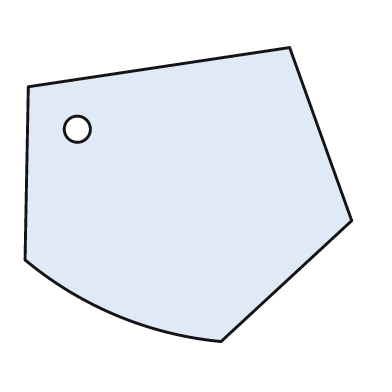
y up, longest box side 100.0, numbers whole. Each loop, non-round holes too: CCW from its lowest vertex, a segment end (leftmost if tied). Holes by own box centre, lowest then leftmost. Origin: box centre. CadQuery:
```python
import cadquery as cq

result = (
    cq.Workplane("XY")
    .moveTo(10.0, -45.0)
    .lineTo(50.0, -8.0)
    .lineTo(31.0, 45.0)
    .lineTo(-49.0, 33.0)
    .lineTo(-50.0, -20.0)
    .threePointArc((-22.0, -37.0), (10.0, -45.0))
    .close()
    .moveTo(-34.0, 20.0)
    .circle(4.0)
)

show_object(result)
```